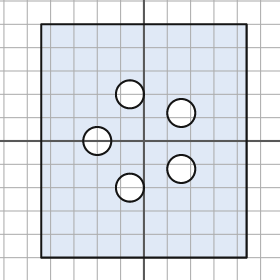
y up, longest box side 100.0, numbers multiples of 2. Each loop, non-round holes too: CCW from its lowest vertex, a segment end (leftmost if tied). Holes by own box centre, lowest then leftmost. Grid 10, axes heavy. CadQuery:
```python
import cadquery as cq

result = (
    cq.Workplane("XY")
    .moveTo(-44.0, -50.0)
    .lineTo(44.0, -50.0)
    .lineTo(44.0, 50.0)
    .lineTo(-44.0, 50.0)
    .close()
    .moveTo(-6.0, -20.0)
    .circle(6.0)
    .moveTo(16.0, -12.0)
    .circle(6.0)
    .moveTo(-20.0, 0.0)
    .circle(6.0)
    .moveTo(16.0, 12.0)
    .circle(6.0)
    .moveTo(-6.0, 20.0)
    .circle(6.0)
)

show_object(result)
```